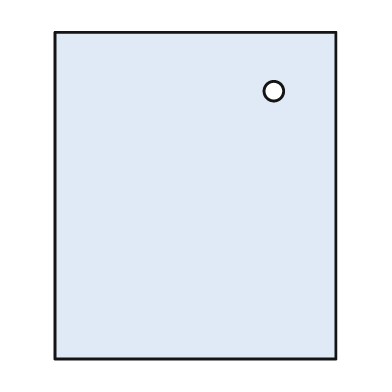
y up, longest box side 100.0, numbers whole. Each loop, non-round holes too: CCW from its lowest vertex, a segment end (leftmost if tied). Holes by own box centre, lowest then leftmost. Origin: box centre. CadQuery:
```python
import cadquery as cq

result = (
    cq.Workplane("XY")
    .moveTo(-43.0, -50.0)
    .lineTo(43.0, -50.0)
    .lineTo(43.0, 50.0)
    .lineTo(-43.0, 50.0)
    .close()
    .moveTo(24.0, 32.0)
    .circle(3.0)
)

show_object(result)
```